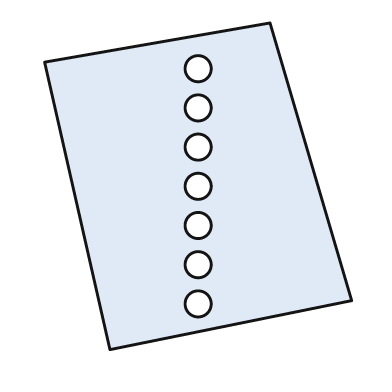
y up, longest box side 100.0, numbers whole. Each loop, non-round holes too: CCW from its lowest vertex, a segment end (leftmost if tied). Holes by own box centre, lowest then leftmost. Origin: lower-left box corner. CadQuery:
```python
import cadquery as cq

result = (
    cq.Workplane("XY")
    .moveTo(20.0, 0.0)
    .lineTo(94.0, 15.0)
    .lineTo(69.0, 100.0)
    .lineTo(0.0, 88.0)
    .close()
    .moveTo(47.0, 14.0)
    .circle(4.0)
    .moveTo(47.0, 26.0)
    .circle(4.0)
    .moveTo(47.0, 38.0)
    .circle(4.0)
    .moveTo(47.0, 50.0)
    .circle(4.0)
    .moveTo(47.0, 62.0)
    .circle(4.0)
    .moveTo(47.0, 74.0)
    .circle(4.0)
    .moveTo(47.0, 86.0)
    .circle(4.0)
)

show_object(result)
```